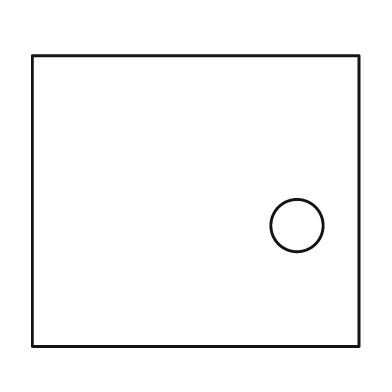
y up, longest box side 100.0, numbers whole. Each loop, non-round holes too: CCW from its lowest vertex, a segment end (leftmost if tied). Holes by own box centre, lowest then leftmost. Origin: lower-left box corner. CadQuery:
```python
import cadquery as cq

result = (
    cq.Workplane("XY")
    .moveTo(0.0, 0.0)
    .lineTo(100.0, 0.0)
    .lineTo(100.0, 89.0)
    .lineTo(0.0, 89.0)
    .close()
    .moveTo(81.0, 37.0)
    .circle(8.0)
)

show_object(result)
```